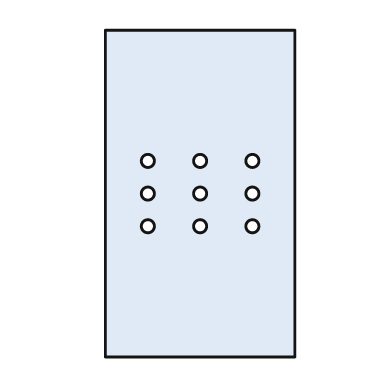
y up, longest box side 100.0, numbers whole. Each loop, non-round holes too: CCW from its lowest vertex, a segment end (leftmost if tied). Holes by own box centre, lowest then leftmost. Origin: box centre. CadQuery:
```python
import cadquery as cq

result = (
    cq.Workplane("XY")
    .moveTo(-29.0, -50.0)
    .lineTo(29.0, -50.0)
    .lineTo(29.0, 50.0)
    .lineTo(-29.0, 50.0)
    .close()
    .moveTo(-16.0, -10.0)
    .circle(2.0)
    .moveTo(0.0, -10.0)
    .circle(2.0)
    .moveTo(16.0, -10.0)
    .circle(2.0)
    .moveTo(-16.0, 0.0)
    .circle(2.0)
    .moveTo(0.0, 0.0)
    .circle(2.0)
    .moveTo(16.0, 0.0)
    .circle(2.0)
    .moveTo(-16.0, 10.0)
    .circle(2.0)
    .moveTo(0.0, 10.0)
    .circle(2.0)
    .moveTo(16.0, 10.0)
    .circle(2.0)
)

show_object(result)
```